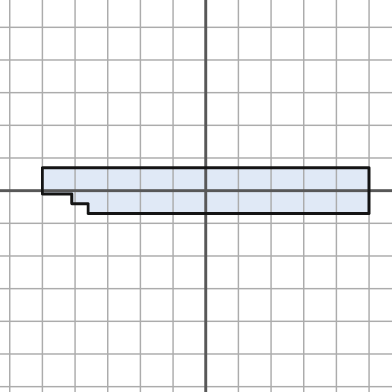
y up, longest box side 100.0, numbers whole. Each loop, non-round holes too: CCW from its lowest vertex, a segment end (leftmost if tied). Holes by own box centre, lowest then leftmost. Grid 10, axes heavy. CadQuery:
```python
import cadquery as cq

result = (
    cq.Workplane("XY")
    .moveTo(-36.0, -7.0)
    .lineTo(50.0, -7.0)
    .lineTo(50.0, 7.0)
    .lineTo(-50.0, 7.0)
    .lineTo(-50.0, -1.0)
    .lineTo(-41.0, -1.0)
    .lineTo(-41.0, -4.0)
    .lineTo(-36.0, -4.0)
    .close()
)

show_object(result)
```